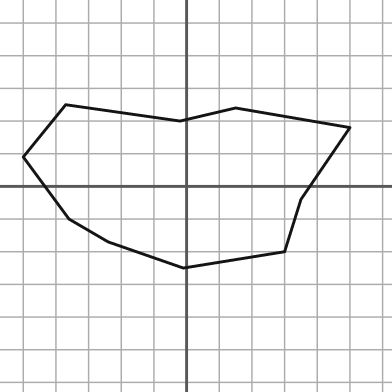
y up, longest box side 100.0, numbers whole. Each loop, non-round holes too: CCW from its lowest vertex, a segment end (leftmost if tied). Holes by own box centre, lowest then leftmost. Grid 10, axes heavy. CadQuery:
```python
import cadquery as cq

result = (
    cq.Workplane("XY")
    .moveTo(-1.0, -25.0)
    .lineTo(30.0, -20.0)
    .lineTo(35.0, -4.0)
    .lineTo(50.0, 18.0)
    .lineTo(15.0, 24.0)
    .lineTo(-2.0, 20.0)
    .lineTo(-37.0, 25.0)
    .lineTo(-50.0, 9.0)
    .lineTo(-36.0, -10.0)
    .lineTo(-24.0, -17.0)
    .close()
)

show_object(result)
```